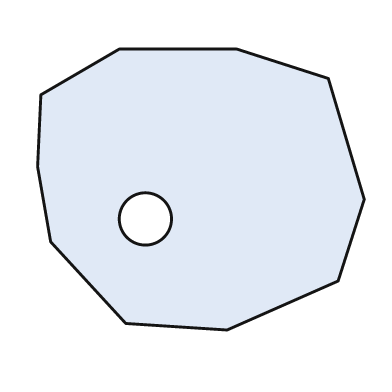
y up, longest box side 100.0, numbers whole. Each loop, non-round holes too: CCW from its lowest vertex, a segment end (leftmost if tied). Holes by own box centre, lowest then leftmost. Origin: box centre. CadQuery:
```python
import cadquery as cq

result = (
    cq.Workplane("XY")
    .moveTo(8.0, -43.0)
    .lineTo(42.0, -28.0)
    .lineTo(50.0, -3.0)
    .lineTo(39.0, 34.0)
    .lineTo(11.0, 43.0)
    .lineTo(-25.0, 43.0)
    .lineTo(-49.0, 29.0)
    .lineTo(-50.0, 7.0)
    .lineTo(-46.0, -16.0)
    .lineTo(-23.0, -41.0)
    .close()
    .moveTo(-17.0, -9.0)
    .circle(8.0)
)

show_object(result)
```